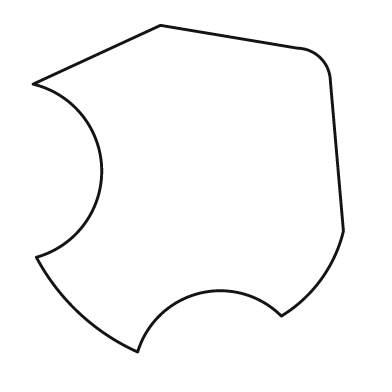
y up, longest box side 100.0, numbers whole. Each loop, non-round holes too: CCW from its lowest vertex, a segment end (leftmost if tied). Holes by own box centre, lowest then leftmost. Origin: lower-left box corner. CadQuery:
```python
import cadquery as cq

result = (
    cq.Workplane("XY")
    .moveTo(32.0, 0.0)
    .threePointArc((51.0, 18.0), (76.0, 11.0))
    .threePointArc((88.0, 22.0), (95.0, 37.0))
    .lineTo(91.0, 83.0)
    .threePointArc((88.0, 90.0), (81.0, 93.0))
    .lineTo(39.0, 100.0)
    .lineTo(0.0, 82.0)
    .threePointArc((21.0, 56.0), (1.0, 29.0))
    .threePointArc((14.0, 12.0), (32.0, 0.0))
    .close()
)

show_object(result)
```